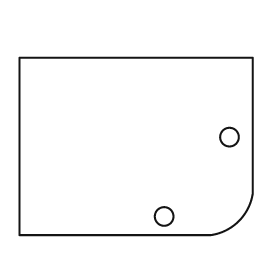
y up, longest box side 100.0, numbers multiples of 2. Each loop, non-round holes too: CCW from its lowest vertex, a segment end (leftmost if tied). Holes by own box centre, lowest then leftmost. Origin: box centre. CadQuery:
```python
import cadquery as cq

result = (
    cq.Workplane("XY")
    .moveTo(-50.0, -38.0)
    .lineTo(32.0, -38.0)
    .threePointArc((44.0, -32.0), (50.0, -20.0))
    .lineTo(50.0, 38.0)
    .lineTo(-50.0, 38.0)
    .close()
    .moveTo(12.0, -30.0)
    .circle(4.0)
    .moveTo(40.0, 4.0)
    .circle(4.0)
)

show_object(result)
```